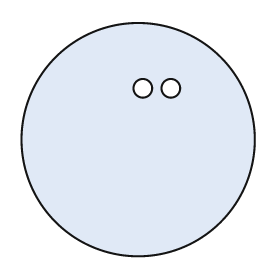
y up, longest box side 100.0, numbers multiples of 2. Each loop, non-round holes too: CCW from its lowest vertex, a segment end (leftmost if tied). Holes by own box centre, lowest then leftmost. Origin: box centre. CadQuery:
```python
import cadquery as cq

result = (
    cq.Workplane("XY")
    .moveTo(0.0, 0.0)
    .circle(50.0)
    .moveTo(2.0, 22.0)
    .circle(4.0)
    .moveTo(14.0, 22.0)
    .circle(4.0)
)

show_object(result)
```